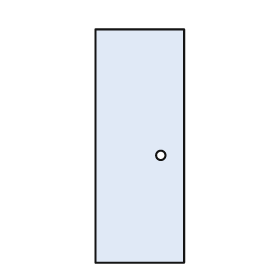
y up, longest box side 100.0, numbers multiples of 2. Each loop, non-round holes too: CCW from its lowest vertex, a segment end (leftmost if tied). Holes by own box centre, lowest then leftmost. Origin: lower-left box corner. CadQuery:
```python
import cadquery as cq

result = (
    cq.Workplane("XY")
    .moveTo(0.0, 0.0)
    .lineTo(38.0, 0.0)
    .lineTo(38.0, 100.0)
    .lineTo(0.0, 100.0)
    .close()
    .moveTo(28.0, 46.0)
    .circle(2.0)
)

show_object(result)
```